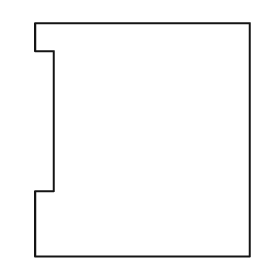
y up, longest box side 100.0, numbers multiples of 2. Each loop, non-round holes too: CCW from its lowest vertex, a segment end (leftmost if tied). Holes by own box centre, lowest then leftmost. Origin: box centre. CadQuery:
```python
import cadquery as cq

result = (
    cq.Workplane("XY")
    .moveTo(-46.0, -50.0)
    .lineTo(46.0, -50.0)
    .lineTo(46.0, 50.0)
    .lineTo(-46.0, 50.0)
    .lineTo(-46.0, 38.0)
    .lineTo(-38.0, 38.0)
    .lineTo(-38.0, -22.0)
    .lineTo(-46.0, -22.0)
    .close()
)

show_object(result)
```